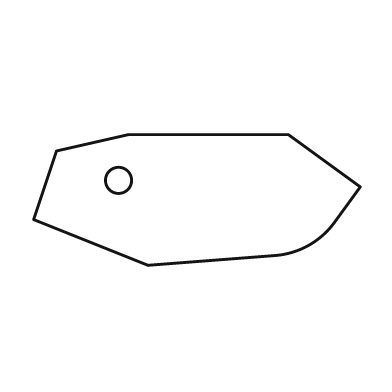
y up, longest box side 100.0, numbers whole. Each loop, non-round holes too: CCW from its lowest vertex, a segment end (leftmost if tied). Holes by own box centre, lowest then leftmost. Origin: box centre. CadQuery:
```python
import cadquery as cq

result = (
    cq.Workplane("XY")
    .moveTo(-15.0, -20.0)
    .lineTo(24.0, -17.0)
    .threePointArc((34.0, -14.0), (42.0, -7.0))
    .lineTo(50.0, 4.0)
    .lineTo(28.0, 20.0)
    .lineTo(-21.0, 20.0)
    .lineTo(-43.0, 15.0)
    .lineTo(-50.0, -6.0)
    .close()
    .moveTo(-24.0, 6.0)
    .circle(4.0)
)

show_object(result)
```